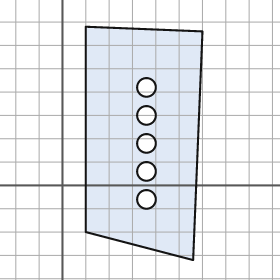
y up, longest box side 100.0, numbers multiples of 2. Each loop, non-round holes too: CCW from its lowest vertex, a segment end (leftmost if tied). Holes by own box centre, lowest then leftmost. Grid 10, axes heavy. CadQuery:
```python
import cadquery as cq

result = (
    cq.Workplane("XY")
    .moveTo(56.0, -32.0)
    .lineTo(60.0, 66.0)
    .lineTo(10.0, 68.0)
    .lineTo(10.0, -20.0)
    .close()
    .moveTo(36.0, -6.0)
    .circle(4.0)
    .moveTo(36.0, 6.0)
    .circle(4.0)
    .moveTo(36.0, 18.0)
    .circle(4.0)
    .moveTo(36.0, 30.0)
    .circle(4.0)
    .moveTo(36.0, 42.0)
    .circle(4.0)
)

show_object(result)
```